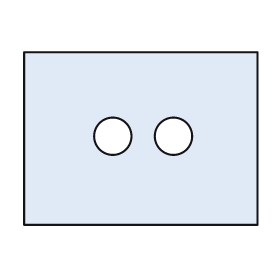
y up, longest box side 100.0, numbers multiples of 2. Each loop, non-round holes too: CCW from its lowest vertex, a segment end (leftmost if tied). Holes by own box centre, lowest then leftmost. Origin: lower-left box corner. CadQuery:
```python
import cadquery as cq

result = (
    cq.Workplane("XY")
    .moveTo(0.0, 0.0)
    .lineTo(100.0, 0.0)
    .lineTo(100.0, 74.0)
    .lineTo(0.0, 74.0)
    .close()
    .moveTo(38.0, 38.0)
    .circle(8.0)
    .moveTo(64.0, 38.0)
    .circle(8.0)
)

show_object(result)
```